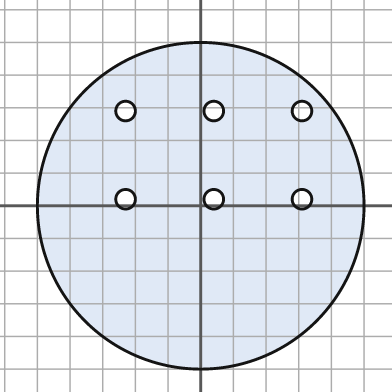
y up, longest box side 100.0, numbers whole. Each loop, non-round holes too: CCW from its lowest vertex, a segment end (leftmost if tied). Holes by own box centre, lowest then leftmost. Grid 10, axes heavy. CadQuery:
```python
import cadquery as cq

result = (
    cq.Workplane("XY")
    .moveTo(0.0, 0.0)
    .circle(50.0)
    .moveTo(-23.0, 2.0)
    .circle(3.0)
    .moveTo(4.0, 2.0)
    .circle(3.0)
    .moveTo(31.0, 2.0)
    .circle(3.0)
    .moveTo(-23.0, 29.0)
    .circle(3.0)
    .moveTo(4.0, 29.0)
    .circle(3.0)
    .moveTo(31.0, 29.0)
    .circle(3.0)
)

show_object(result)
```